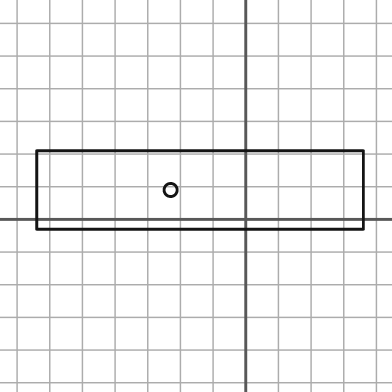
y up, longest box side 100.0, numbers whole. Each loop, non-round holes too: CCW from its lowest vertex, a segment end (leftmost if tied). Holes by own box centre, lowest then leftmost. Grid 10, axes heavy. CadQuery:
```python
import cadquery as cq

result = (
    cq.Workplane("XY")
    .moveTo(-64.0, -3.0)
    .lineTo(36.0, -3.0)
    .lineTo(36.0, 21.0)
    .lineTo(-64.0, 21.0)
    .close()
    .moveTo(-23.0, 9.0)
    .circle(2.0)
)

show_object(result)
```